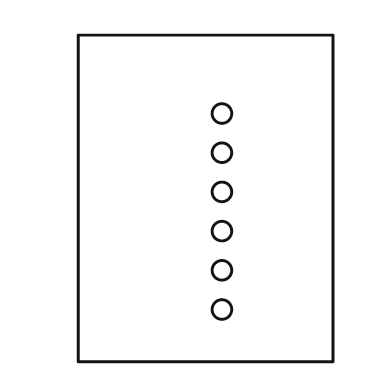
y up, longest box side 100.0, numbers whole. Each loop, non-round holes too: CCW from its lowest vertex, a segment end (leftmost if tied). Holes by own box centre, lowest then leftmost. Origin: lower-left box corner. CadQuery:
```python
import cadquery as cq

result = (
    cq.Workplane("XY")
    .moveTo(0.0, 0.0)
    .lineTo(78.0, 0.0)
    .lineTo(78.0, 100.0)
    .lineTo(0.0, 100.0)
    .close()
    .moveTo(44.0, 16.0)
    .circle(3.0)
    .moveTo(44.0, 28.0)
    .circle(3.0)
    .moveTo(44.0, 40.0)
    .circle(3.0)
    .moveTo(44.0, 52.0)
    .circle(3.0)
    .moveTo(44.0, 64.0)
    .circle(3.0)
    .moveTo(44.0, 76.0)
    .circle(3.0)
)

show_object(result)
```